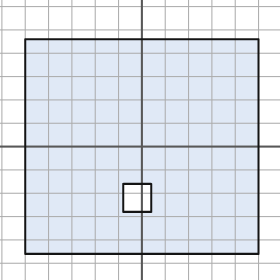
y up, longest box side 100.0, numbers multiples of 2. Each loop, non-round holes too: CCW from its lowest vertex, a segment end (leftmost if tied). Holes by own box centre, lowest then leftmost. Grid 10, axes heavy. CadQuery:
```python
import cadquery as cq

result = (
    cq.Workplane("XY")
    .moveTo(-50.0, -46.0)
    .lineTo(50.0, -46.0)
    .lineTo(50.0, 46.0)
    .lineTo(-50.0, 46.0)
    .close()
    .moveTo(-8.0, -28.0)
    .lineTo(4.0, -28.0)
    .lineTo(4.0, -16.0)
    .lineTo(-8.0, -16.0)
    .close()
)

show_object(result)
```